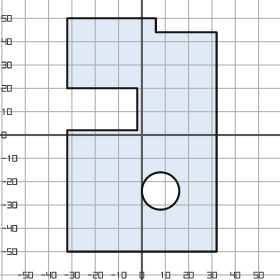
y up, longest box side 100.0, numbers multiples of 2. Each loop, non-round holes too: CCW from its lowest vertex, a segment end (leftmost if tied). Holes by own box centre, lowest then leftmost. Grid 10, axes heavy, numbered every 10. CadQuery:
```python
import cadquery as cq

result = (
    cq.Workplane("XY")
    .moveTo(-32.0, -50.0)
    .lineTo(32.0, -50.0)
    .lineTo(32.0, 44.0)
    .lineTo(6.0, 44.0)
    .lineTo(6.0, 50.0)
    .lineTo(-32.0, 50.0)
    .lineTo(-32.0, 20.0)
    .lineTo(-2.0, 20.0)
    .lineTo(-2.0, 2.0)
    .lineTo(-32.0, 2.0)
    .close()
    .moveTo(8.0, -24.0)
    .circle(8.0)
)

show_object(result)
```